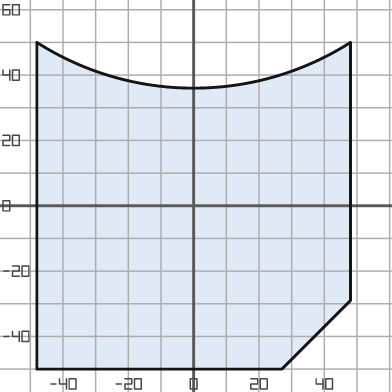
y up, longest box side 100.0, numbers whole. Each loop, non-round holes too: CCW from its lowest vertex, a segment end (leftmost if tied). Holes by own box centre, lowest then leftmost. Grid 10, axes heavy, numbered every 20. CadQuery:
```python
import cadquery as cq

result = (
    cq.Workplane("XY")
    .moveTo(-48.0, -50.0)
    .lineTo(27.0, -50.0)
    .lineTo(48.0, -29.0)
    .lineTo(48.0, 50.0)
    .threePointArc((0.0, 36.0), (-48.0, 50.0))
    .close()
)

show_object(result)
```